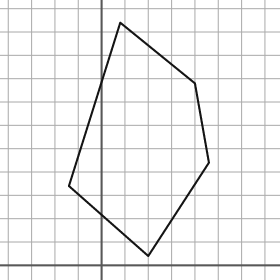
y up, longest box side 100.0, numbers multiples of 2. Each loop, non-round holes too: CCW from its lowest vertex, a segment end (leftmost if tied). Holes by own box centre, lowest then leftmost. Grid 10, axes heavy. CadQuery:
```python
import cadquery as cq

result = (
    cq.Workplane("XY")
    .moveTo(20.0, 4.0)
    .lineTo(46.0, 44.0)
    .lineTo(40.0, 78.0)
    .lineTo(8.0, 104.0)
    .lineTo(-14.0, 34.0)
    .close()
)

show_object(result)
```